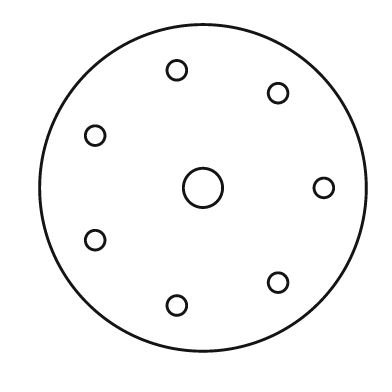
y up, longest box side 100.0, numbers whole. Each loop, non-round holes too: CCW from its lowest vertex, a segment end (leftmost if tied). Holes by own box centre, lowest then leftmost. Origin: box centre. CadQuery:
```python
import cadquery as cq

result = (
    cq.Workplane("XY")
    .moveTo(0.0, 0.0)
    .circle(50.0)
    .moveTo(-8.0, -36.0)
    .circle(3.0)
    .moveTo(23.0, -29.0)
    .circle(3.0)
    .moveTo(-33.0, -16.0)
    .circle(3.0)
    .moveTo(0.0, 0.0)
    .circle(6.0)
    .moveTo(37.0, 0.0)
    .circle(3.0)
    .moveTo(-33.0, 16.0)
    .circle(3.0)
    .moveTo(23.0, 29.0)
    .circle(3.0)
    .moveTo(-8.0, 36.0)
    .circle(3.0)
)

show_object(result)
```